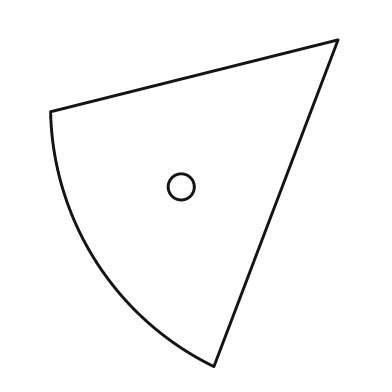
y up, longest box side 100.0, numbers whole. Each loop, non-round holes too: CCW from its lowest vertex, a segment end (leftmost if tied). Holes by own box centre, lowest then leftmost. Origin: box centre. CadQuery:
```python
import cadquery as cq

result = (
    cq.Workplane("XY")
    .moveTo(6.0, -50.0)
    .lineTo(44.0, 50.0)
    .lineTo(-44.0, 28.0)
    .threePointArc((-30.0, -18.0), (6.0, -50.0))
    .close()
    .moveTo(-4.0, 5.0)
    .circle(4.0)
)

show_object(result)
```